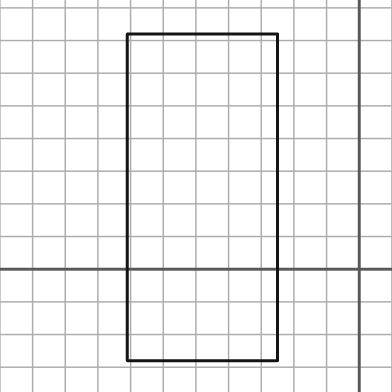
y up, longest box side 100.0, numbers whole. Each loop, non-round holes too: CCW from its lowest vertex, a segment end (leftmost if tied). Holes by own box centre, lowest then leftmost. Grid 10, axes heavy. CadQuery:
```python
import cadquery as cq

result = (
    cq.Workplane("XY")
    .moveTo(-71.0, -28.0)
    .lineTo(-25.0, -28.0)
    .lineTo(-25.0, 72.0)
    .lineTo(-71.0, 72.0)
    .close()
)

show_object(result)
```